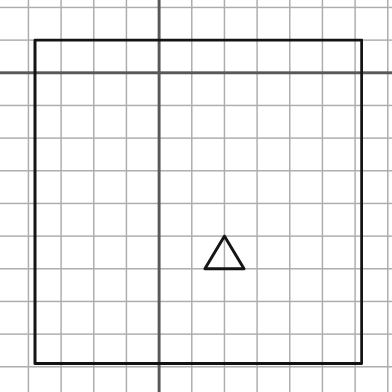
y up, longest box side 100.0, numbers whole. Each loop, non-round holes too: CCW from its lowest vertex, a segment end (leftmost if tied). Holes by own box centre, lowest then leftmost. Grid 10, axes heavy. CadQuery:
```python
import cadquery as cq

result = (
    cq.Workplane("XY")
    .moveTo(-38.0, -89.0)
    .lineTo(62.0, -89.0)
    .lineTo(62.0, 10.0)
    .lineTo(-38.0, 10.0)
    .close()
    .moveTo(14.0, -60.0)
    .lineTo(26.0, -60.0)
    .lineTo(20.0, -50.0)
    .close()
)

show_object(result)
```